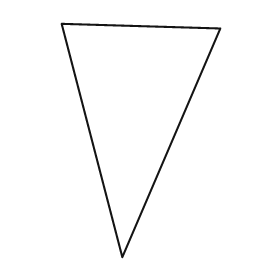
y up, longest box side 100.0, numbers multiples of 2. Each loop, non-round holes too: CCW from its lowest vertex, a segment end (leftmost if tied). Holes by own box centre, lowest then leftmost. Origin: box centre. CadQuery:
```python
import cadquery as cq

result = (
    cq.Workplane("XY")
    .moveTo(-8.0, -50.0)
    .lineTo(34.0, 48.0)
    .lineTo(-34.0, 50.0)
    .close()
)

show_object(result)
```